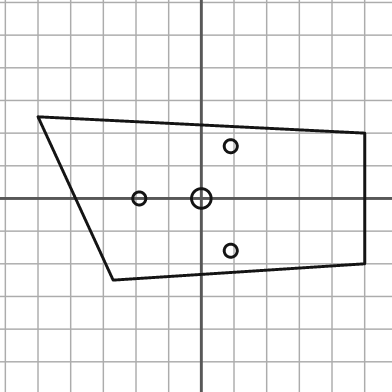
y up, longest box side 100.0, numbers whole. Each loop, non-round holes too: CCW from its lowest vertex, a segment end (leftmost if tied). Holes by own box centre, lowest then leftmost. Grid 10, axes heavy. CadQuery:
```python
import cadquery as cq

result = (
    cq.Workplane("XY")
    .moveTo(-27.0, -25.0)
    .lineTo(50.0, -20.0)
    .lineTo(50.0, 20.0)
    .lineTo(-50.0, 25.0)
    .close()
    .moveTo(9.0, -16.0)
    .circle(2.0)
    .moveTo(-19.0, 0.0)
    .circle(2.0)
    .moveTo(0.0, 0.0)
    .circle(3.0)
    .moveTo(9.0, 16.0)
    .circle(2.0)
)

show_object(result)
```